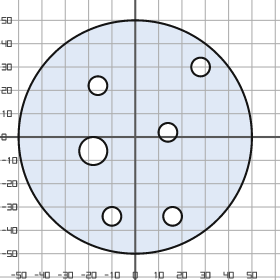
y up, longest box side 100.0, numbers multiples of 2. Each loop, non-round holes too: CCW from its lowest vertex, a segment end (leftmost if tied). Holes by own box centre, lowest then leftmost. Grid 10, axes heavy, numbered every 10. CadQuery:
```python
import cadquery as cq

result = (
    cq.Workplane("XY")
    .moveTo(0.0, 0.0)
    .circle(50.0)
    .moveTo(-10.0, -34.0)
    .circle(4.0)
    .moveTo(16.0, -34.0)
    .circle(4.0)
    .moveTo(-18.0, -6.0)
    .circle(6.0)
    .moveTo(14.0, 2.0)
    .circle(4.0)
    .moveTo(-16.0, 22.0)
    .circle(4.0)
    .moveTo(28.0, 30.0)
    .circle(4.0)
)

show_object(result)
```